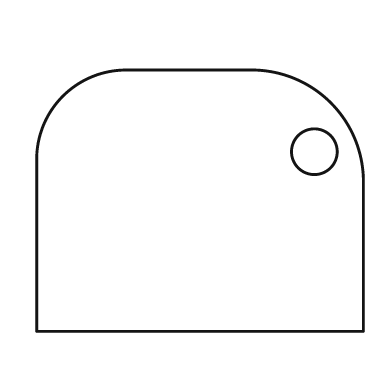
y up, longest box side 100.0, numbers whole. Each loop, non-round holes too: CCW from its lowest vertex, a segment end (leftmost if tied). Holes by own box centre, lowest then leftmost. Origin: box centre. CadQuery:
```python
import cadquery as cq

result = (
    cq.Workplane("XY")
    .moveTo(-50.0, -40.0)
    .lineTo(50.0, -40.0)
    .lineTo(50.0, 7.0)
    .threePointArc((40.0, 30.0), (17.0, 40.0))
    .lineTo(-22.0, 40.0)
    .threePointArc((-42.0, 32.0), (-50.0, 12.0))
    .close()
    .moveTo(35.0, 15.0)
    .circle(7.0)
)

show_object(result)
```